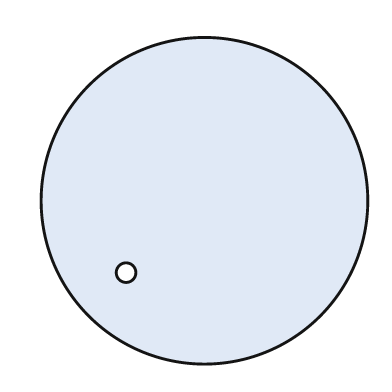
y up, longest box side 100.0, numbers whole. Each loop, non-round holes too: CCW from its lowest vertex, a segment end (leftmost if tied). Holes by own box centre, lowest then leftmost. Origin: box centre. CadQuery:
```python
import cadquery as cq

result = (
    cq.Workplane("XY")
    .moveTo(0.0, 0.0)
    .circle(50.0)
    .moveTo(-24.0, -22.0)
    .circle(3.0)
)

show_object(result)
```